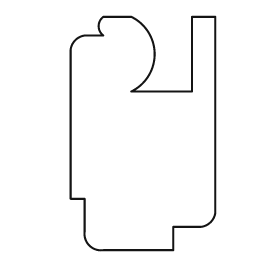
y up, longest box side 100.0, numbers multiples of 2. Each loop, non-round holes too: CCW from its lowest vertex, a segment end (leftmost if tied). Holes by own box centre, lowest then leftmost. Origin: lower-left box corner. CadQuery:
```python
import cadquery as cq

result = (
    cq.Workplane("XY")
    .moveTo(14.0, 0.0)
    .lineTo(44.0, 0.0)
    .lineTo(44.0, 10.0)
    .lineTo(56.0, 10.0)
    .threePointArc((60.0, 12.0), (62.0, 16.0))
    .lineTo(62.0, 100.0)
    .lineTo(52.0, 100.0)
    .lineTo(52.0, 68.0)
    .lineTo(26.0, 68.0)
    .threePointArc((36.0, 84.0), (26.0, 100.0))
    .lineTo(14.0, 100.0)
    .threePointArc((12.0, 96.0), (14.0, 92.0))
    .lineTo(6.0, 92.0)
    .threePointArc((2.0, 90.0), (0.0, 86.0))
    .lineTo(0.0, 22.0)
    .lineTo(6.0, 22.0)
    .lineTo(6.0, 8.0)
    .threePointArc((8.0, 2.0), (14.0, 0.0))
    .close()
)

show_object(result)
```